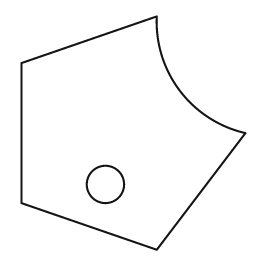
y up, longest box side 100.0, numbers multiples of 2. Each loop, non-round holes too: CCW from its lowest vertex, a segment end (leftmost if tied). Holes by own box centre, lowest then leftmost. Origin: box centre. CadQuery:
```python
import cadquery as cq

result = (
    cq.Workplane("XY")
    .moveTo(10.0, -50.0)
    .lineTo(48.0, 0.0)
    .threePointArc((20.0, 18.0), (10.0, 50.0))
    .lineTo(-48.0, 30.0)
    .lineTo(-48.0, -30.0)
    .close()
    .moveTo(-12.0, -22.0)
    .circle(8.0)
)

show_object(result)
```